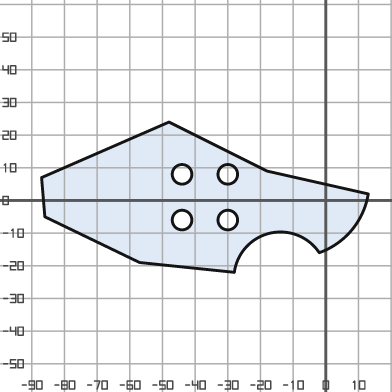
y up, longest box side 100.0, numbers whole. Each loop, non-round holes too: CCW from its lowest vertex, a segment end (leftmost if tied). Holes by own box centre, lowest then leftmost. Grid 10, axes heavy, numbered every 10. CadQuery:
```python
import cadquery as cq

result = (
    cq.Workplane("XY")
    .moveTo(-28.0, -22.0)
    .threePointArc((-17.0, -10.0), (-2.0, -16.0))
    .threePointArc((8.0, -9.0), (13.0, 2.0))
    .lineTo(-18.0, 9.0)
    .lineTo(-48.0, 24.0)
    .lineTo(-87.0, 7.0)
    .lineTo(-86.0, -5.0)
    .lineTo(-57.0, -19.0)
    .close()
    .moveTo(-44.0, -6.0)
    .circle(3.0)
    .moveTo(-30.0, -6.0)
    .circle(3.0)
    .moveTo(-44.0, 8.0)
    .circle(3.0)
    .moveTo(-30.0, 8.0)
    .circle(3.0)
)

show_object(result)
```